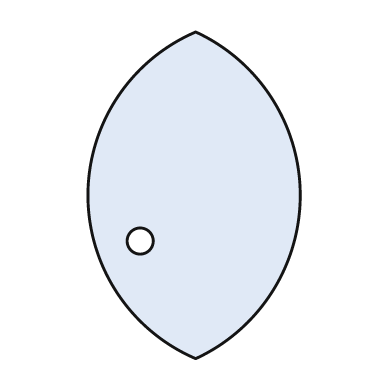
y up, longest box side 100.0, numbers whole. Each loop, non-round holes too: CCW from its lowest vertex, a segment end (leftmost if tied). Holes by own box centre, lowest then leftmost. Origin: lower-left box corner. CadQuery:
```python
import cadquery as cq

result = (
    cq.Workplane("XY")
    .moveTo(33.0, 0.0)
    .threePointArc((65.0, 50.0), (33.0, 100.0))
    .threePointArc((0.0, 50.0), (33.0, 0.0))
    .close()
    .moveTo(16.0, 36.0)
    .circle(4.0)
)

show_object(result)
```